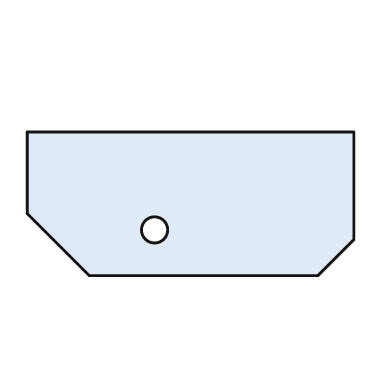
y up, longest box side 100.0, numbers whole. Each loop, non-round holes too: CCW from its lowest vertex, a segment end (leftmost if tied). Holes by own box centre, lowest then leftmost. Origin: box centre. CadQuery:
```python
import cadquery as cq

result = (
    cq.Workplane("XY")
    .moveTo(-31.0, -22.0)
    .lineTo(39.0, -22.0)
    .lineTo(50.0, -11.0)
    .lineTo(50.0, 22.0)
    .lineTo(-50.0, 22.0)
    .lineTo(-50.0, -3.0)
    .close()
    .moveTo(-11.0, -8.0)
    .circle(4.0)
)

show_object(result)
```